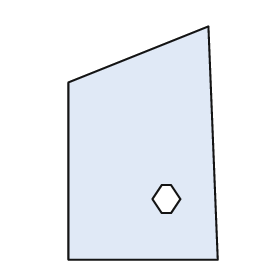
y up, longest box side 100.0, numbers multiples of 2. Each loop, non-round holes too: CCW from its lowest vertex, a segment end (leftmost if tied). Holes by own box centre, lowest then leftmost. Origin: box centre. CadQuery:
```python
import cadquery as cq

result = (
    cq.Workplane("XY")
    .moveTo(-32.0, -50.0)
    .lineTo(32.0, -50.0)
    .lineTo(28.0, 50.0)
    .lineTo(-32.0, 26.0)
    .close()
    .moveTo(8.0, -30.0)
    .lineTo(12.0, -30.0)
    .lineTo(16.0, -24.0)
    .lineTo(12.0, -18.0)
    .lineTo(8.0, -18.0)
    .lineTo(4.0, -24.0)
    .close()
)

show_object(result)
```